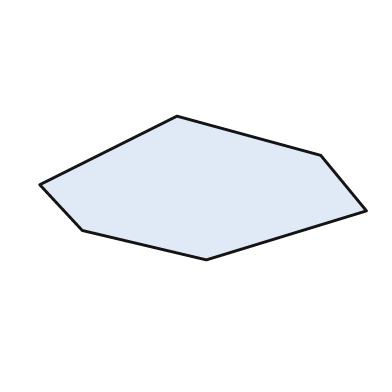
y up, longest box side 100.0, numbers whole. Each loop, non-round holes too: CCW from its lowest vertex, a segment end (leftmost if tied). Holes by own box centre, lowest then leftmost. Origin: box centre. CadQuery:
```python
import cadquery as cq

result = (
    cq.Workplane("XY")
    .moveTo(1.0, -22.0)
    .lineTo(50.0, -7.0)
    .lineTo(36.0, 10.0)
    .lineTo(-8.0, 22.0)
    .lineTo(-50.0, 1.0)
    .lineTo(-37.0, -13.0)
    .close()
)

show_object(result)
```